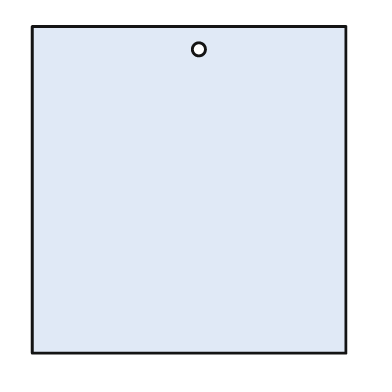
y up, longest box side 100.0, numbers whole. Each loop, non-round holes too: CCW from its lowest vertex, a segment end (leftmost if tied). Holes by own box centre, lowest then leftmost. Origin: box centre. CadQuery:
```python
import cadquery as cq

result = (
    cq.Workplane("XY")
    .moveTo(-48.0, -50.0)
    .lineTo(48.0, -50.0)
    .lineTo(48.0, 50.0)
    .lineTo(-48.0, 50.0)
    .close()
    .moveTo(3.0, 43.0)
    .circle(2.0)
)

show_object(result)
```